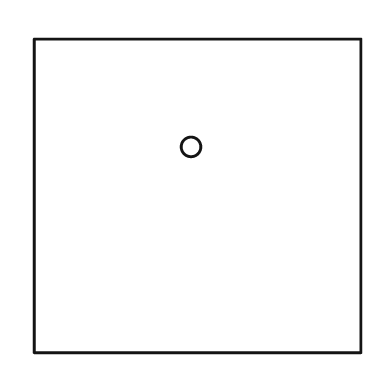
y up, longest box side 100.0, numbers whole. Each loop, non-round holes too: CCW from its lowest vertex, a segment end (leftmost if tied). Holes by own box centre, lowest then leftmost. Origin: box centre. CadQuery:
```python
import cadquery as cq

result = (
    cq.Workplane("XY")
    .moveTo(-50.0, -48.0)
    .lineTo(50.0, -48.0)
    .lineTo(50.0, 48.0)
    .lineTo(-50.0, 48.0)
    .close()
    .moveTo(-2.0, 15.0)
    .circle(3.0)
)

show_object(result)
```